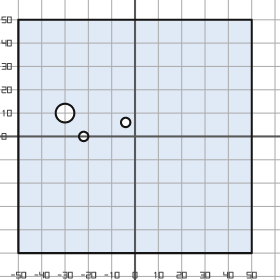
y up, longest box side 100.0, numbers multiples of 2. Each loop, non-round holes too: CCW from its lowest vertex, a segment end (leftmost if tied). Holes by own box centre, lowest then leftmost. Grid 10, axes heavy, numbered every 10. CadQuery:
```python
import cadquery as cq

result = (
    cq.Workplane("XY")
    .moveTo(-50.0, -50.0)
    .lineTo(50.0, -50.0)
    .lineTo(50.0, 50.0)
    .lineTo(-50.0, 50.0)
    .close()
    .moveTo(-22.0, 0.0)
    .circle(2.0)
    .moveTo(-4.0, 6.0)
    .circle(2.0)
    .moveTo(-30.0, 10.0)
    .circle(4.0)
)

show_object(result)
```